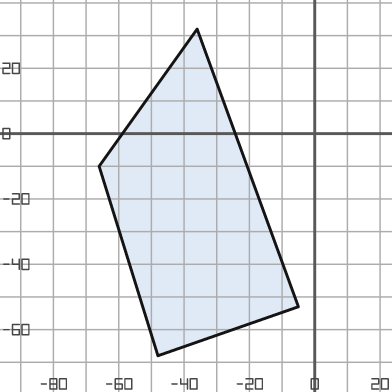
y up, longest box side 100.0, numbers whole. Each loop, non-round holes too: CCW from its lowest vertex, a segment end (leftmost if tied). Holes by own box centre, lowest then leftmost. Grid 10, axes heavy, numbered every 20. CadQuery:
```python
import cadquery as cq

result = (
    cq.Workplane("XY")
    .moveTo(-48.0, -68.0)
    .lineTo(-5.0, -53.0)
    .lineTo(-36.0, 32.0)
    .lineTo(-66.0, -10.0)
    .close()
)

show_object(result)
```